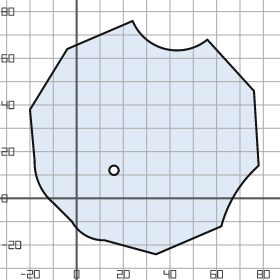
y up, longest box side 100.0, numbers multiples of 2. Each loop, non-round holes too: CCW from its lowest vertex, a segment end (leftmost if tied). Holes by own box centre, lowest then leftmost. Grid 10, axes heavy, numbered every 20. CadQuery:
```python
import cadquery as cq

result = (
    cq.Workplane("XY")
    .moveTo(34.0, -24.0)
    .lineTo(62.0, -12.0)
    .threePointArc((68.0, 2.0), (78.0, 14.0))
    .lineTo(76.0, 46.0)
    .lineTo(56.0, 68.0)
    .threePointArc((38.0, 64.0), (24.0, 76.0))
    .lineTo(-4.0, 64.0)
    .lineTo(-20.0, 38.0)
    .lineTo(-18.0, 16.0)
    .threePointArc((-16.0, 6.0), (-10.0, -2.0))
    .lineTo(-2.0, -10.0)
    .threePointArc((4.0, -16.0), (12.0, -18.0))
    .close()
    .moveTo(16.0, 12.0)
    .circle(2.0)
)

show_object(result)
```